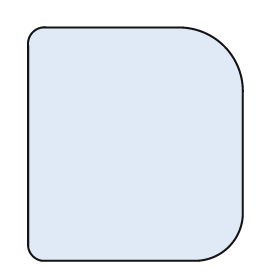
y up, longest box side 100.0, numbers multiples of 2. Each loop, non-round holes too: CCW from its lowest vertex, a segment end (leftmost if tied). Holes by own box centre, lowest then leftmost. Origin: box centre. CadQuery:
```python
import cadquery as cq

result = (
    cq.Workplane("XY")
    .moveTo(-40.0, -50.0)
    .lineTo(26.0, -50.0)
    .threePointArc((40.0, -44.0), (46.0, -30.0))
    .lineTo(46.0, 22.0)
    .threePointArc((38.0, 42.0), (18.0, 50.0))
    .lineTo(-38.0, 50.0)
    .threePointArc((-44.0, 48.0), (-46.0, 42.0))
    .lineTo(-46.0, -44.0)
    .threePointArc((-44.0, -48.0), (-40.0, -50.0))
    .close()
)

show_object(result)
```